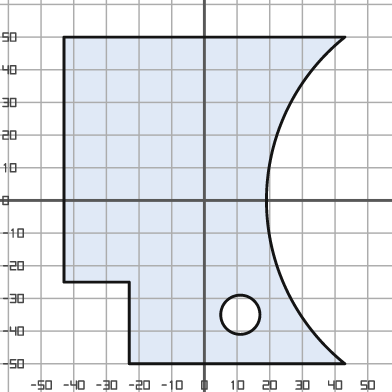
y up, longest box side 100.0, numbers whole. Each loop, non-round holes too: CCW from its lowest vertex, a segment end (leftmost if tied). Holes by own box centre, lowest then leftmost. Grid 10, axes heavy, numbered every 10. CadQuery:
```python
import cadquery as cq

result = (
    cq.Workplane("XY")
    .moveTo(-23.0, -50.0)
    .lineTo(43.0, -50.0)
    .threePointArc((19.0, 0.0), (43.0, 50.0))
    .lineTo(-43.0, 50.0)
    .lineTo(-43.0, -25.0)
    .lineTo(-23.0, -25.0)
    .close()
    .moveTo(11.0, -35.0)
    .circle(6.0)
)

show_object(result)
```